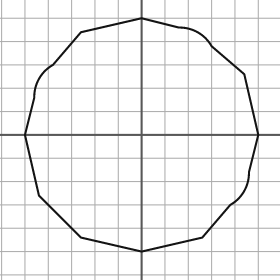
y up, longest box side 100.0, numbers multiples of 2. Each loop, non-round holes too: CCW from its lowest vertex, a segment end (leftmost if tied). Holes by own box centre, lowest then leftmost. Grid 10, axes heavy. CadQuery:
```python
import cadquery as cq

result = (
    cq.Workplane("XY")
    .moveTo(0.0, -50.0)
    .lineTo(26.0, -44.0)
    .lineTo(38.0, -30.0)
    .threePointArc((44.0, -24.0), (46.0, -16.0))
    .lineTo(50.0, 0.0)
    .lineTo(44.0, 26.0)
    .lineTo(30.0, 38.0)
    .threePointArc((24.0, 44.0), (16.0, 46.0))
    .lineTo(0.0, 50.0)
    .lineTo(-26.0, 44.0)
    .lineTo(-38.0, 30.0)
    .threePointArc((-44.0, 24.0), (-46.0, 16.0))
    .lineTo(-50.0, 0.0)
    .lineTo(-44.0, -26.0)
    .lineTo(-26.0, -44.0)
    .close()
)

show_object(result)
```